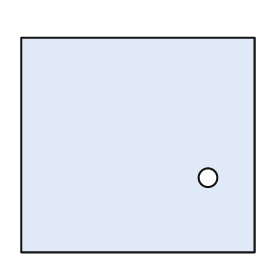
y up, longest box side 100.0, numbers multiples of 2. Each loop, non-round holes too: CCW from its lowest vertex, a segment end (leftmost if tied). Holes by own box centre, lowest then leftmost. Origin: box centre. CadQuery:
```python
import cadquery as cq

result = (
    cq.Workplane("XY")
    .moveTo(-50.0, -46.0)
    .lineTo(50.0, -46.0)
    .lineTo(50.0, 46.0)
    .lineTo(-50.0, 46.0)
    .close()
    .moveTo(30.0, -14.0)
    .circle(4.0)
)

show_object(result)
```